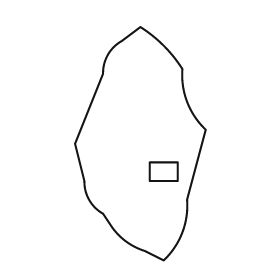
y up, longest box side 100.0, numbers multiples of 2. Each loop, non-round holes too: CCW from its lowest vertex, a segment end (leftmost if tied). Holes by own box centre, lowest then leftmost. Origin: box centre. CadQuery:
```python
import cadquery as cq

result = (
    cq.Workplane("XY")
    .moveTo(10.0, -50.0)
    .threePointArc((18.0, -38.0), (20.0, -24.0))
    .lineTo(28.0, 6.0)
    .threePointArc((20.0, 18.0), (18.0, 32.0))
    .threePointArc((10.0, 42.0), (0.0, 50.0))
    .lineTo(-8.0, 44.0)
    .threePointArc((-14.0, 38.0), (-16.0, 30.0))
    .lineTo(-28.0, 0.0)
    .lineTo(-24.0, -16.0)
    .threePointArc((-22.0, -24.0), (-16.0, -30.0))
    .lineTo(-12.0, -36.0)
    .threePointArc((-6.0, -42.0), (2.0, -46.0))
    .close()
    .moveTo(4.0, -16.0)
    .lineTo(16.0, -16.0)
    .lineTo(16.0, -8.0)
    .lineTo(4.0, -8.0)
    .close()
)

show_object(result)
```